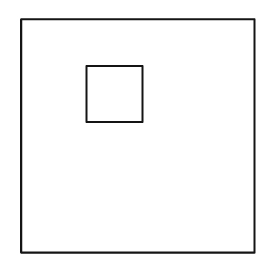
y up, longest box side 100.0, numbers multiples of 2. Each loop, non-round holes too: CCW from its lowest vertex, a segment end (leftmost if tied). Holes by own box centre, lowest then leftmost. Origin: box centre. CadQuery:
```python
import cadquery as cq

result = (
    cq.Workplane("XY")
    .moveTo(-50.0, -50.0)
    .lineTo(50.0, -50.0)
    .lineTo(50.0, 50.0)
    .lineTo(-50.0, 50.0)
    .close()
    .moveTo(-22.0, 6.0)
    .lineTo(2.0, 6.0)
    .lineTo(2.0, 30.0)
    .lineTo(-22.0, 30.0)
    .close()
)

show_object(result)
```